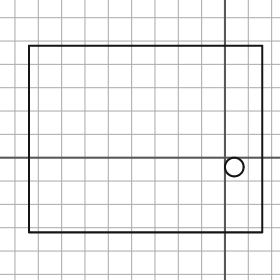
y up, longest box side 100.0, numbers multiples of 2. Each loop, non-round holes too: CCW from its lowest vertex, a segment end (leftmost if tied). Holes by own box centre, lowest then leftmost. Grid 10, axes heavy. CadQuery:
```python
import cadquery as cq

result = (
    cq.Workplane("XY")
    .moveTo(-84.0, -32.0)
    .lineTo(16.0, -32.0)
    .lineTo(16.0, 48.0)
    .lineTo(-84.0, 48.0)
    .close()
    .moveTo(4.0, -4.0)
    .circle(4.0)
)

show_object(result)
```